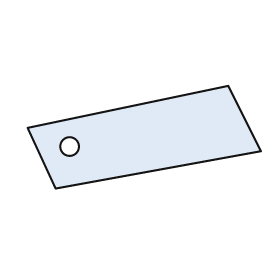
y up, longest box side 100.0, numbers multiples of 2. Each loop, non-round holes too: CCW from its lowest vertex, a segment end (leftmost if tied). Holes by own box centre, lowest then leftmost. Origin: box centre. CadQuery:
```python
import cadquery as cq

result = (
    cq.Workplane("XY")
    .moveTo(-38.0, -22.0)
    .lineTo(50.0, -6.0)
    .lineTo(36.0, 22.0)
    .lineTo(-50.0, 4.0)
    .close()
    .moveTo(-32.0, -4.0)
    .circle(4.0)
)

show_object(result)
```